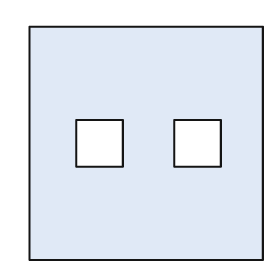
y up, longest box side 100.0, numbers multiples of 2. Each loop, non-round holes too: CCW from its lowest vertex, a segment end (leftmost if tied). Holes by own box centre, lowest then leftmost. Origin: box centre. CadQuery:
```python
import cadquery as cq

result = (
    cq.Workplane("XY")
    .moveTo(-50.0, -50.0)
    .lineTo(50.0, -50.0)
    .lineTo(50.0, 50.0)
    .lineTo(-50.0, 50.0)
    .close()
    .moveTo(-30.0, -10.0)
    .lineTo(-10.0, -10.0)
    .lineTo(-10.0, 10.0)
    .lineTo(-30.0, 10.0)
    .close()
    .moveTo(12.0, -10.0)
    .lineTo(32.0, -10.0)
    .lineTo(32.0, 10.0)
    .lineTo(12.0, 10.0)
    .close()
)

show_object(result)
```